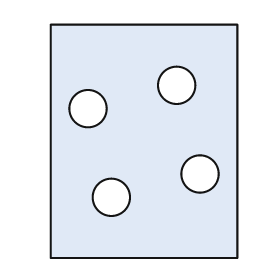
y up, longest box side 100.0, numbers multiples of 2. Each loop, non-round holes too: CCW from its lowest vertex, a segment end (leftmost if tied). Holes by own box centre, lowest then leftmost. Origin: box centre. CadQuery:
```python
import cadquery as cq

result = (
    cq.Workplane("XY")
    .moveTo(-40.0, -50.0)
    .lineTo(40.0, -50.0)
    .lineTo(40.0, 50.0)
    .lineTo(-40.0, 50.0)
    .close()
    .moveTo(-14.0, -24.0)
    .circle(8.0)
    .moveTo(24.0, -14.0)
    .circle(8.0)
    .moveTo(-24.0, 14.0)
    .circle(8.0)
    .moveTo(14.0, 24.0)
    .circle(8.0)
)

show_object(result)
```